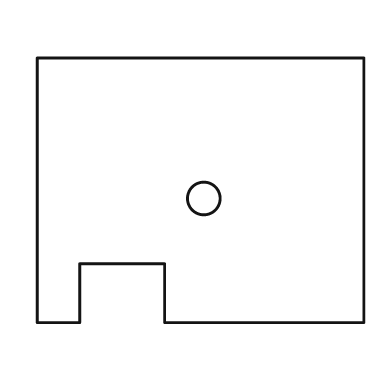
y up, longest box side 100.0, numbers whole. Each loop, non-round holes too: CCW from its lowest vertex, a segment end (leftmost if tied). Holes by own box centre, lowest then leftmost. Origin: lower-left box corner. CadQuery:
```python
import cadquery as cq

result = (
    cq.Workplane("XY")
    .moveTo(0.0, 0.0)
    .lineTo(13.0, 0.0)
    .lineTo(13.0, 18.0)
    .lineTo(39.0, 18.0)
    .lineTo(39.0, 0.0)
    .lineTo(100.0, 0.0)
    .lineTo(100.0, 81.0)
    .lineTo(0.0, 81.0)
    .close()
    .moveTo(51.0, 38.0)
    .circle(5.0)
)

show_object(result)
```